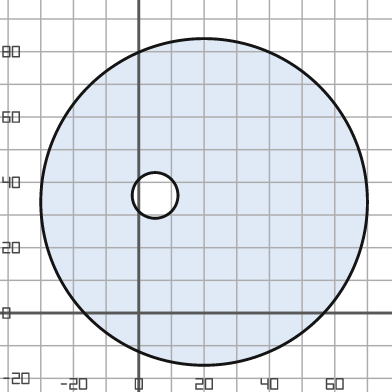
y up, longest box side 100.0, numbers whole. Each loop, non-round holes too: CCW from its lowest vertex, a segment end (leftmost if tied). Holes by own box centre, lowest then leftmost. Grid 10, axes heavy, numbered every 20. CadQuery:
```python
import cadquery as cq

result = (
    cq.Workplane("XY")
    .moveTo(20.0, 34.0)
    .circle(50.0)
    .moveTo(5.0, 36.0)
    .circle(7.0)
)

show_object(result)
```